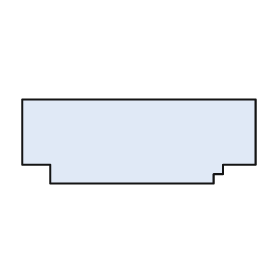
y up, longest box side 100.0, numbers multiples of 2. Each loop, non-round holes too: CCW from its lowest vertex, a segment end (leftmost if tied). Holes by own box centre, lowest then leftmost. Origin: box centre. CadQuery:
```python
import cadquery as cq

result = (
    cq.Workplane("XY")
    .moveTo(-38.0, -18.0)
    .lineTo(32.0, -18.0)
    .lineTo(32.0, -14.0)
    .lineTo(36.0, -14.0)
    .lineTo(36.0, -10.0)
    .lineTo(50.0, -10.0)
    .lineTo(50.0, 18.0)
    .lineTo(-50.0, 18.0)
    .lineTo(-50.0, -10.0)
    .lineTo(-38.0, -10.0)
    .close()
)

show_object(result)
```